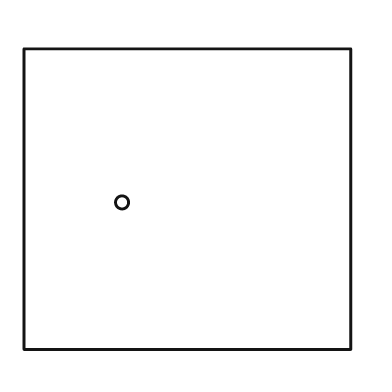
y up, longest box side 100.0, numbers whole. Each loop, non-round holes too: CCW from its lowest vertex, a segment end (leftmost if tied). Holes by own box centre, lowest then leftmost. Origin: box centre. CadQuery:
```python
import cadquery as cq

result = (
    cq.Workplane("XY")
    .moveTo(-50.0, -46.0)
    .lineTo(50.0, -46.0)
    .lineTo(50.0, 46.0)
    .lineTo(-50.0, 46.0)
    .close()
    .moveTo(-20.0, -1.0)
    .circle(2.0)
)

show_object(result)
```